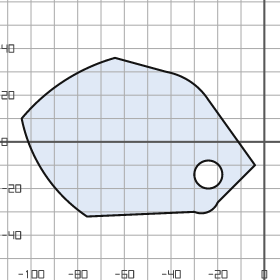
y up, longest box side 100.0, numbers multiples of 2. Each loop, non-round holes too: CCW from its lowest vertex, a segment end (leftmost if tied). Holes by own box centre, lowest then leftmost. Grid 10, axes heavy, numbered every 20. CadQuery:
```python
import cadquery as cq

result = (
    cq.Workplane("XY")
    .moveTo(-76.0, -32.0)
    .lineTo(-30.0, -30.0)
    .threePointArc((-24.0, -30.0), (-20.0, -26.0))
    .lineTo(-4.0, -10.0)
    .lineTo(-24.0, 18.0)
    .threePointArc((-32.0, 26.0), (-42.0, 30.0))
    .lineTo(-64.0, 36.0)
    .threePointArc((-86.0, 26.0), (-104.0, 10.0))
    .threePointArc((-94.0, -14.0), (-76.0, -32.0))
    .close()
    .moveTo(-24.0, -14.0)
    .circle(6.0)
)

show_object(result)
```